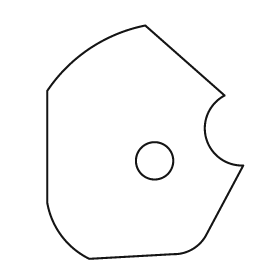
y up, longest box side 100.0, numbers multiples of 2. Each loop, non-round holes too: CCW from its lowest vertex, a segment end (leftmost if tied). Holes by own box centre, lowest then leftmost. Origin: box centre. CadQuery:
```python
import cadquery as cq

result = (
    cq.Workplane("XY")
    .moveTo(-24.0, -50.0)
    .lineTo(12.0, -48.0)
    .threePointArc((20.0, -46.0), (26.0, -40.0))
    .lineTo(42.0, -10.0)
    .threePointArc((26.0, 2.0), (34.0, 20.0))
    .lineTo(0.0, 50.0)
    .threePointArc((-24.0, 40.0), (-42.0, 22.0))
    .lineTo(-42.0, -26.0)
    .threePointArc((-36.0, -40.0), (-24.0, -50.0))
    .close()
    .moveTo(4.0, -8.0)
    .circle(8.0)
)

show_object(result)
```